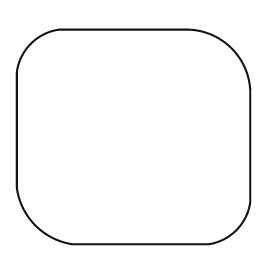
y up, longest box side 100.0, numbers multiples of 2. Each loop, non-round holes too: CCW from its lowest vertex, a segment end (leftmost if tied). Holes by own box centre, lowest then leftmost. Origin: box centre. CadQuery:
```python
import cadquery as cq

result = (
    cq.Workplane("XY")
    .moveTo(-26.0, -46.0)
    .lineTo(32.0, -46.0)
    .threePointArc((44.0, -40.0), (50.0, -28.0))
    .lineTo(50.0, 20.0)
    .threePointArc((42.0, 38.0), (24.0, 46.0))
    .lineTo(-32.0, 46.0)
    .threePointArc((-44.0, 40.0), (-50.0, 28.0))
    .lineTo(-50.0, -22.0)
    .threePointArc((-42.0, -38.0), (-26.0, -46.0))
    .close()
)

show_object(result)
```